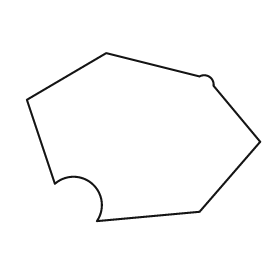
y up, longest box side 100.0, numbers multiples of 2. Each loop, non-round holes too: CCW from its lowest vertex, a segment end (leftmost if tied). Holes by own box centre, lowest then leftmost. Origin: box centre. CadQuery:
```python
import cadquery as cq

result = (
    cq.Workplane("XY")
    .moveTo(-20.0, -36.0)
    .lineTo(24.0, -32.0)
    .lineTo(50.0, -2.0)
    .lineTo(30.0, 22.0)
    .threePointArc((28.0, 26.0), (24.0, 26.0))
    .lineTo(-16.0, 36.0)
    .lineTo(-50.0, 16.0)
    .lineTo(-38.0, -20.0)
    .threePointArc((-22.0, -20.0), (-20.0, -36.0))
    .close()
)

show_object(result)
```